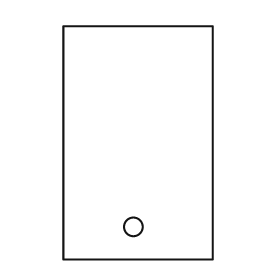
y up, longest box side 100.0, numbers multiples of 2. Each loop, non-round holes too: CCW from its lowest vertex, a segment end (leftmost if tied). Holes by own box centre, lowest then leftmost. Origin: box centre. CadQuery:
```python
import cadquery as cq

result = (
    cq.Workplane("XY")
    .moveTo(-32.0, -50.0)
    .lineTo(32.0, -50.0)
    .lineTo(32.0, 50.0)
    .lineTo(-32.0, 50.0)
    .close()
    .moveTo(-2.0, -36.0)
    .circle(4.0)
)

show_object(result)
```